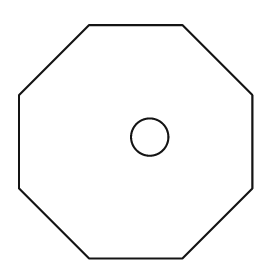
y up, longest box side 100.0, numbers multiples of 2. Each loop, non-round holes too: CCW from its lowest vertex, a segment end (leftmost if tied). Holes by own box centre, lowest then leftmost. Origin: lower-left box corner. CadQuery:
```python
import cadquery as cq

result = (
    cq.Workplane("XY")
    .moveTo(30.0, 0.0)
    .lineTo(70.0, 0.0)
    .lineTo(100.0, 30.0)
    .lineTo(100.0, 70.0)
    .lineTo(70.0, 100.0)
    .lineTo(30.0, 100.0)
    .lineTo(0.0, 70.0)
    .lineTo(0.0, 30.0)
    .close()
    .moveTo(56.0, 52.0)
    .circle(8.0)
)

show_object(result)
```